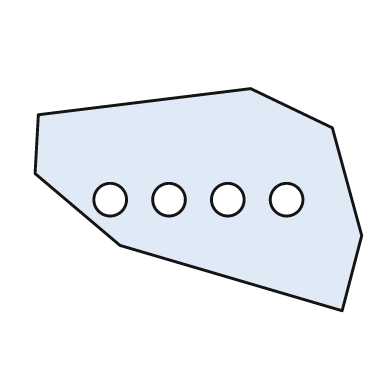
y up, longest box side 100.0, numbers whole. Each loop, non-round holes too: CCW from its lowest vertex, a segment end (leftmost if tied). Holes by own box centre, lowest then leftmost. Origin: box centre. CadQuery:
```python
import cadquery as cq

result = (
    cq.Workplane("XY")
    .moveTo(44.0, -34.0)
    .lineTo(50.0, -11.0)
    .lineTo(41.0, 22.0)
    .lineTo(16.0, 34.0)
    .lineTo(-49.0, 26.0)
    .lineTo(-50.0, 8.0)
    .lineTo(-24.0, -14.0)
    .close()
    .moveTo(-27.0, 0.0)
    .circle(5.0)
    .moveTo(-9.0, 0.0)
    .circle(5.0)
    .moveTo(9.0, 0.0)
    .circle(5.0)
    .moveTo(27.0, 0.0)
    .circle(5.0)
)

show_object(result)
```